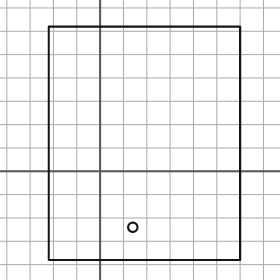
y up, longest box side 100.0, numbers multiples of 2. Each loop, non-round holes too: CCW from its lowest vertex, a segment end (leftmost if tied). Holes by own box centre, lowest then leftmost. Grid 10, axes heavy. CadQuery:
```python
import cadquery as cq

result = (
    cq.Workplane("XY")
    .moveTo(-22.0, -38.0)
    .lineTo(60.0, -38.0)
    .lineTo(60.0, 62.0)
    .lineTo(-22.0, 62.0)
    .close()
    .moveTo(14.0, -24.0)
    .circle(2.0)
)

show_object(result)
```